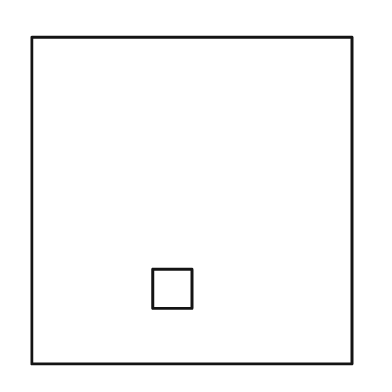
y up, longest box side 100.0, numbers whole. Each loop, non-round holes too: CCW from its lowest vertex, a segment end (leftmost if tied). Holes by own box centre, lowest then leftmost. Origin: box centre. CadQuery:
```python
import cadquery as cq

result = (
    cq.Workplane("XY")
    .moveTo(-49.0, -50.0)
    .lineTo(49.0, -50.0)
    .lineTo(49.0, 50.0)
    .lineTo(-49.0, 50.0)
    .close()
    .moveTo(-12.0, -33.0)
    .lineTo(0.0, -33.0)
    .lineTo(0.0, -21.0)
    .lineTo(-12.0, -21.0)
    .close()
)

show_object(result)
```